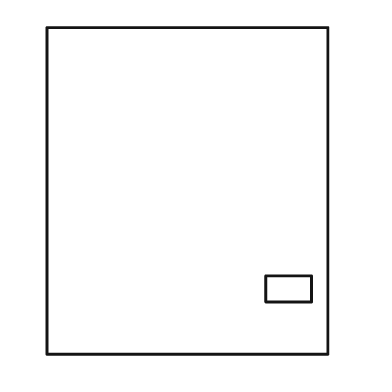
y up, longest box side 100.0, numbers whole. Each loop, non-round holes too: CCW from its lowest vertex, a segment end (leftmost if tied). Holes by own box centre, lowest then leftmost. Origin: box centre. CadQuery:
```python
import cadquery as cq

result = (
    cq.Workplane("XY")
    .moveTo(-43.0, -50.0)
    .lineTo(43.0, -50.0)
    .lineTo(43.0, 50.0)
    .lineTo(-43.0, 50.0)
    .close()
    .moveTo(24.0, -34.0)
    .lineTo(38.0, -34.0)
    .lineTo(38.0, -26.0)
    .lineTo(24.0, -26.0)
    .close()
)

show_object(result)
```